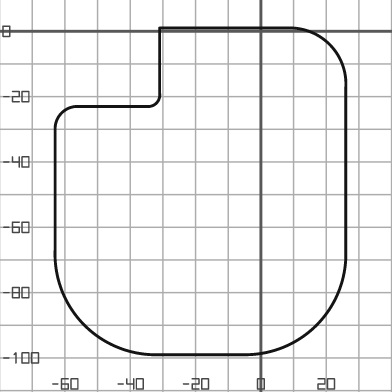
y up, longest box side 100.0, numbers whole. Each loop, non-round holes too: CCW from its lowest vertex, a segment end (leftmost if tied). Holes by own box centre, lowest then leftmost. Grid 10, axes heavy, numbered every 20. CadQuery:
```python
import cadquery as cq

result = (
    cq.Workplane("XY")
    .moveTo(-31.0, -99.0)
    .lineTo(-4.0, -99.0)
    .threePointArc((17.0, -90.0), (26.0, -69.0))
    .lineTo(26.0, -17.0)
    .threePointArc((21.0, -4.0), (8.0, 1.0))
    .lineTo(-31.0, 1.0)
    .lineTo(-31.0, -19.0)
    .threePointArc((-32.0, -22.0), (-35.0, -23.0))
    .lineTo(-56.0, -23.0)
    .threePointArc((-61.0, -25.0), (-63.0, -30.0))
    .lineTo(-63.0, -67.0)
    .threePointArc((-54.0, -90.0), (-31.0, -99.0))
    .close()
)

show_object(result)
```